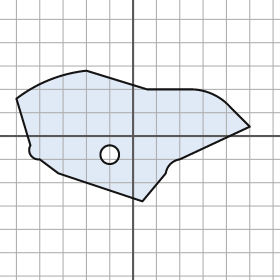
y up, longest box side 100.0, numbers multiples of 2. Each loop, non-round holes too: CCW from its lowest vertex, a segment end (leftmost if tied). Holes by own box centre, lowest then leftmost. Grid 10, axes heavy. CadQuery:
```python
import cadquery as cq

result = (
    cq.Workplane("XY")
    .moveTo(4.0, -28.0)
    .lineTo(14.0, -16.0)
    .threePointArc((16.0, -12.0), (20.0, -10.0))
    .lineTo(50.0, 4.0)
    .lineTo(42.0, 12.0)
    .threePointArc((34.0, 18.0), (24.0, 20.0))
    .lineTo(6.0, 20.0)
    .lineTo(-20.0, 28.0)
    .threePointArc((-36.0, 24.0), (-50.0, 16.0))
    .lineTo(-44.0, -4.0)
    .threePointArc((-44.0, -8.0), (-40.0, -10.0))
    .lineTo(-32.0, -16.0)
    .close()
    .moveTo(-10.0, -8.0)
    .circle(4.0)
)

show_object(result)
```